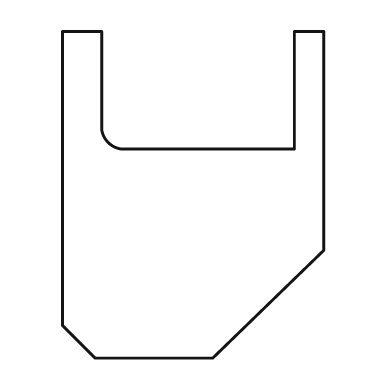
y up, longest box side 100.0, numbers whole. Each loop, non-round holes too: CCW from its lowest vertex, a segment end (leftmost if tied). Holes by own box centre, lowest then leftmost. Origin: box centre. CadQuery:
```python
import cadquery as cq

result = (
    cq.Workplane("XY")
    .moveTo(-30.0, -50.0)
    .lineTo(6.0, -50.0)
    .lineTo(40.0, -17.0)
    .lineTo(40.0, 50.0)
    .lineTo(31.0, 50.0)
    .lineTo(31.0, 14.0)
    .lineTo(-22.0, 14.0)
    .threePointArc((-26.0, 16.0), (-28.0, 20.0))
    .lineTo(-28.0, 50.0)
    .lineTo(-40.0, 50.0)
    .lineTo(-40.0, -40.0)
    .close()
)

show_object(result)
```